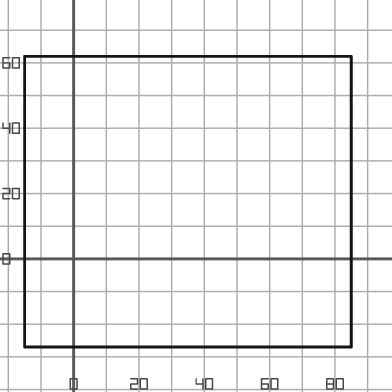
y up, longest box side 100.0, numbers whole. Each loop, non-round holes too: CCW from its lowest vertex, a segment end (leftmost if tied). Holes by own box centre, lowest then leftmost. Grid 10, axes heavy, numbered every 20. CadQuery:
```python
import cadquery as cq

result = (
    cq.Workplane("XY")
    .moveTo(-15.0, -27.0)
    .lineTo(85.0, -27.0)
    .lineTo(85.0, 62.0)
    .lineTo(-15.0, 62.0)
    .close()
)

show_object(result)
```